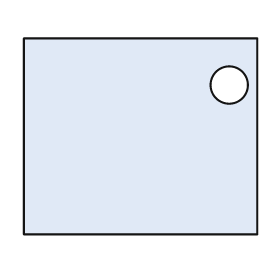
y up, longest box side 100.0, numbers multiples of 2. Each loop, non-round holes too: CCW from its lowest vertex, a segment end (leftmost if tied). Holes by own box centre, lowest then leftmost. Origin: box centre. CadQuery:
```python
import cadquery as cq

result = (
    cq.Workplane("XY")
    .moveTo(-50.0, -42.0)
    .lineTo(50.0, -42.0)
    .lineTo(50.0, 42.0)
    .lineTo(-50.0, 42.0)
    .close()
    .moveTo(38.0, 22.0)
    .circle(8.0)
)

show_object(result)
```